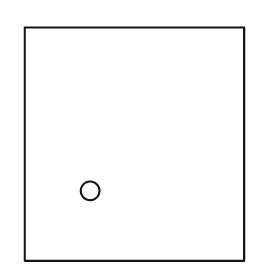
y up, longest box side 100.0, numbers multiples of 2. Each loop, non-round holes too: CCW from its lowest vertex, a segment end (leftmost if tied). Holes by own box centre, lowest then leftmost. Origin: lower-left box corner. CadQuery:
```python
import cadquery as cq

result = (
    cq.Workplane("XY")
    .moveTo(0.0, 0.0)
    .lineTo(94.0, 0.0)
    .lineTo(94.0, 100.0)
    .lineTo(0.0, 100.0)
    .close()
    .moveTo(28.0, 30.0)
    .circle(4.0)
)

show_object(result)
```